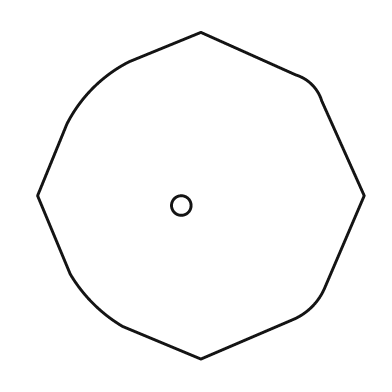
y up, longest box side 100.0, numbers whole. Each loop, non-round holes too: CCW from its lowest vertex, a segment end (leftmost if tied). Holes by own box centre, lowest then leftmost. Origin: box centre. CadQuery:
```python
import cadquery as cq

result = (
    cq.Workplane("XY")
    .moveTo(0.0, -50.0)
    .lineTo(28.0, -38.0)
    .threePointArc((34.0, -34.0), (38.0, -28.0))
    .lineTo(50.0, 0.0)
    .lineTo(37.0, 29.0)
    .threePointArc((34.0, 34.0), (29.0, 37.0))
    .lineTo(0.0, 50.0)
    .lineTo(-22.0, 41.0)
    .threePointArc((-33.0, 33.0), (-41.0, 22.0))
    .lineTo(-50.0, 0.0)
    .lineTo(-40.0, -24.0)
    .threePointArc((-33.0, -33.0), (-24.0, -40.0))
    .close()
    .moveTo(-6.0, -3.0)
    .circle(3.0)
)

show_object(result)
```